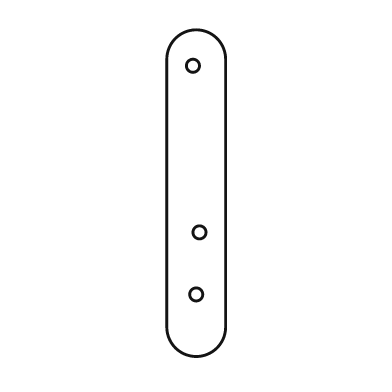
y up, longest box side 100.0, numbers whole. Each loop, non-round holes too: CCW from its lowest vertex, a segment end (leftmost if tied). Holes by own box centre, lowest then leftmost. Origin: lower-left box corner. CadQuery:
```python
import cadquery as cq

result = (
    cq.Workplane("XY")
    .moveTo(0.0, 9.0)
    .threePointArc((9.0, 0.0), (18.0, 9.0))
    .lineTo(18.0, 91.0)
    .threePointArc((9.0, 100.0), (0.0, 91.0))
    .close()
    .moveTo(9.0, 19.0)
    .circle(2.0)
    .moveTo(10.0, 38.0)
    .circle(2.0)
    .moveTo(8.0, 89.0)
    .circle(2.0)
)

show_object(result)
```